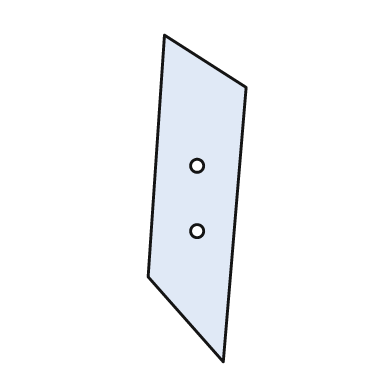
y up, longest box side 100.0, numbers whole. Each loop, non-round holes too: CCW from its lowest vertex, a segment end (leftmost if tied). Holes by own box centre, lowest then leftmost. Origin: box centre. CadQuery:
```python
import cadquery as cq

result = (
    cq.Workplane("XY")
    .moveTo(8.0, -50.0)
    .lineTo(15.0, 34.0)
    .lineTo(-10.0, 50.0)
    .lineTo(-15.0, -24.0)
    .close()
    .moveTo(0.0, -10.0)
    .circle(2.0)
    .moveTo(0.0, 10.0)
    .circle(2.0)
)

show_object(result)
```